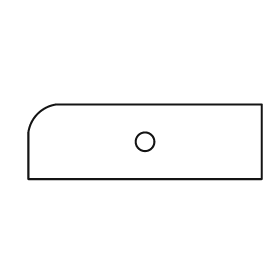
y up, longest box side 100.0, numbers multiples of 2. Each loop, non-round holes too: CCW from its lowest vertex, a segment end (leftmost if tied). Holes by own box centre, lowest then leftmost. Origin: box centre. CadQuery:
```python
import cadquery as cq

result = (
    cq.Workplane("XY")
    .moveTo(-50.0, -16.0)
    .lineTo(50.0, -16.0)
    .lineTo(50.0, 16.0)
    .lineTo(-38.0, 16.0)
    .threePointArc((-46.0, 12.0), (-50.0, 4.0))
    .close()
    .moveTo(0.0, 0.0)
    .circle(4.0)
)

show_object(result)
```